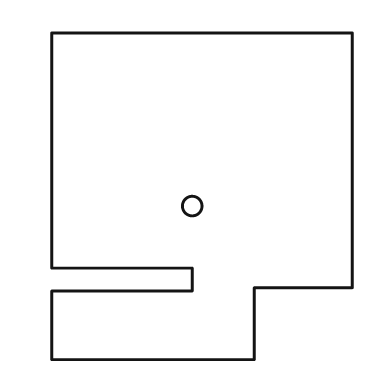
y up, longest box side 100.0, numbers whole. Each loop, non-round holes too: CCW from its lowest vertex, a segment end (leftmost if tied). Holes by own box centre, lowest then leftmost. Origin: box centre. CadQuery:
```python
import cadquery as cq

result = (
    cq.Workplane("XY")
    .moveTo(-46.0, -50.0)
    .lineTo(16.0, -50.0)
    .lineTo(16.0, -28.0)
    .lineTo(46.0, -28.0)
    .lineTo(46.0, 50.0)
    .lineTo(-46.0, 50.0)
    .lineTo(-46.0, -22.0)
    .lineTo(-3.0, -22.0)
    .lineTo(-3.0, -29.0)
    .lineTo(-46.0, -29.0)
    .close()
    .moveTo(-3.0, -3.0)
    .circle(3.0)
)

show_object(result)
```